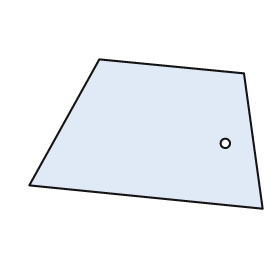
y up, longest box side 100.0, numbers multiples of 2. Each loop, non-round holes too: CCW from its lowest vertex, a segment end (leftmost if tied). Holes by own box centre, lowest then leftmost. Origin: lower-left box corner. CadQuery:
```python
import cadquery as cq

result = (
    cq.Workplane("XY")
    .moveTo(100.0, 0.0)
    .lineTo(92.0, 58.0)
    .lineTo(30.0, 64.0)
    .lineTo(0.0, 10.0)
    .close()
    .moveTo(84.0, 28.0)
    .circle(2.0)
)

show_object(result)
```